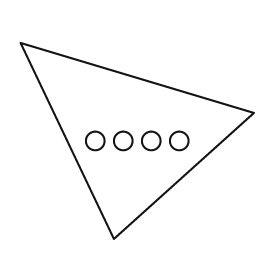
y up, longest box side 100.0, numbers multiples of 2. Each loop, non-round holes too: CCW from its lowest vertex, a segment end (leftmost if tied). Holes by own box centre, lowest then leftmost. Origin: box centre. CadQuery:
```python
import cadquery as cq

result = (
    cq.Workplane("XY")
    .moveTo(-10.0, -42.0)
    .lineTo(50.0, 12.0)
    .lineTo(-50.0, 42.0)
    .close()
    .moveTo(-18.0, 0.0)
    .circle(4.0)
    .moveTo(-6.0, 0.0)
    .circle(4.0)
    .moveTo(6.0, 0.0)
    .circle(4.0)
    .moveTo(18.0, 0.0)
    .circle(4.0)
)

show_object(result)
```